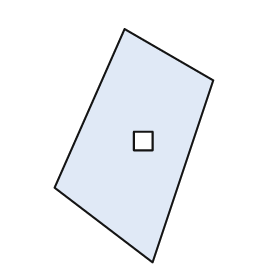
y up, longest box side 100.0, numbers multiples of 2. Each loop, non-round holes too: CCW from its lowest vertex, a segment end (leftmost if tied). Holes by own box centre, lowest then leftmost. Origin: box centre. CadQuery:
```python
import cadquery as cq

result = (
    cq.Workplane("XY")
    .moveTo(8.0, -50.0)
    .lineTo(34.0, 28.0)
    .lineTo(-4.0, 50.0)
    .lineTo(-34.0, -18.0)
    .close()
    .moveTo(0.0, -2.0)
    .lineTo(8.0, -2.0)
    .lineTo(8.0, 6.0)
    .lineTo(0.0, 6.0)
    .close()
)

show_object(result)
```